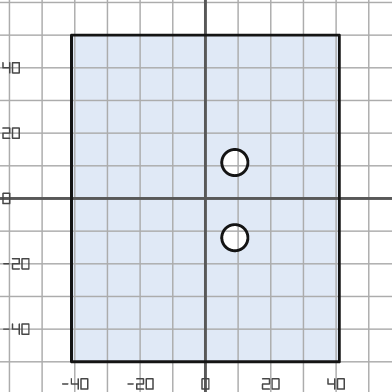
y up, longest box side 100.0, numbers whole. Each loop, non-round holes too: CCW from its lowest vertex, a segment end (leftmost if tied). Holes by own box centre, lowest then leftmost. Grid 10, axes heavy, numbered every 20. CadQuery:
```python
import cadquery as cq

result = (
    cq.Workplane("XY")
    .moveTo(-41.0, -50.0)
    .lineTo(41.0, -50.0)
    .lineTo(41.0, 50.0)
    .lineTo(-41.0, 50.0)
    .close()
    .moveTo(9.0, -12.0)
    .circle(4.0)
    .moveTo(9.0, 11.0)
    .circle(4.0)
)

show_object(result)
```